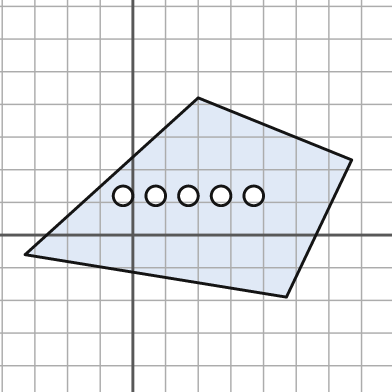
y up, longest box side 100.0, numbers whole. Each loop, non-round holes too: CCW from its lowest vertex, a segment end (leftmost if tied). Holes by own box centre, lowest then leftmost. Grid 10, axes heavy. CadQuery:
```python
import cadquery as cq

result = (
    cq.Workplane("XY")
    .moveTo(47.0, -19.0)
    .lineTo(67.0, 23.0)
    .lineTo(20.0, 42.0)
    .lineTo(-33.0, -6.0)
    .close()
    .moveTo(-3.0, 12.0)
    .circle(3.0)
    .moveTo(7.0, 12.0)
    .circle(3.0)
    .moveTo(17.0, 12.0)
    .circle(3.0)
    .moveTo(27.0, 12.0)
    .circle(3.0)
    .moveTo(37.0, 12.0)
    .circle(3.0)
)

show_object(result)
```